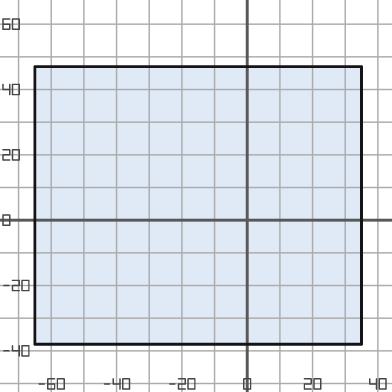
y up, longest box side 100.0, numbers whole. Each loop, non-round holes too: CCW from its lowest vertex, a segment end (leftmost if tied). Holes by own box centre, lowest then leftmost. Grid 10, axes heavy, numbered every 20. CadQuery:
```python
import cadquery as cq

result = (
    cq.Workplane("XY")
    .moveTo(-65.0, -38.0)
    .lineTo(35.0, -38.0)
    .lineTo(35.0, 47.0)
    .lineTo(-65.0, 47.0)
    .close()
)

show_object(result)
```